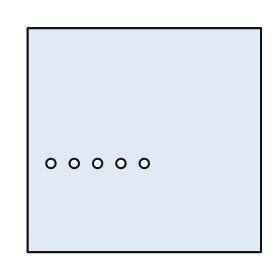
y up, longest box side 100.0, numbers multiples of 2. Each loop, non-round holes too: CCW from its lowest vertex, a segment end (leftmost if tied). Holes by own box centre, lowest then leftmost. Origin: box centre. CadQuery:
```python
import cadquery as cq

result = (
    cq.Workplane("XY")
    .moveTo(-50.0, -48.0)
    .lineTo(50.0, -48.0)
    .lineTo(50.0, 48.0)
    .lineTo(-50.0, 48.0)
    .close()
    .moveTo(-40.0, -10.0)
    .circle(2.0)
    .moveTo(-30.0, -10.0)
    .circle(2.0)
    .moveTo(-20.0, -10.0)
    .circle(2.0)
    .moveTo(-10.0, -10.0)
    .circle(2.0)
    .moveTo(0.0, -10.0)
    .circle(2.0)
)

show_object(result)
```